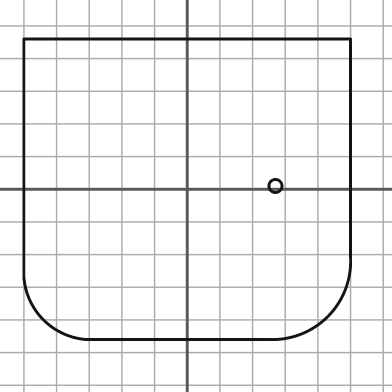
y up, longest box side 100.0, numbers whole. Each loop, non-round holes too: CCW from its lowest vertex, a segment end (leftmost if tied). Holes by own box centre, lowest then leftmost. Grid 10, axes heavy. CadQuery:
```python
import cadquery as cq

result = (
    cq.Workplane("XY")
    .moveTo(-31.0, -46.0)
    .lineTo(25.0, -46.0)
    .threePointArc((43.0, -39.0), (50.0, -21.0))
    .lineTo(50.0, 46.0)
    .lineTo(-50.0, 46.0)
    .lineTo(-50.0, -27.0)
    .threePointArc((-44.0, -40.0), (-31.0, -46.0))
    .close()
    .moveTo(27.0, 1.0)
    .circle(2.0)
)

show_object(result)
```